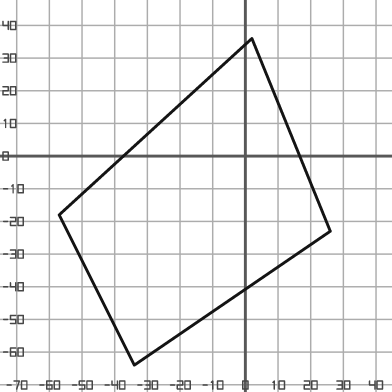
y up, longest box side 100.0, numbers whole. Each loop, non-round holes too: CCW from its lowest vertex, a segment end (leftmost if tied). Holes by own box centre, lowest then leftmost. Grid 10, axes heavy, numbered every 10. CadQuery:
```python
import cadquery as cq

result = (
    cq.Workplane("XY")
    .moveTo(-34.0, -64.0)
    .lineTo(26.0, -23.0)
    .lineTo(2.0, 36.0)
    .lineTo(-57.0, -18.0)
    .close()
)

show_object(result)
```